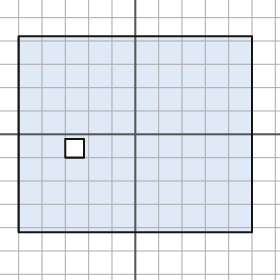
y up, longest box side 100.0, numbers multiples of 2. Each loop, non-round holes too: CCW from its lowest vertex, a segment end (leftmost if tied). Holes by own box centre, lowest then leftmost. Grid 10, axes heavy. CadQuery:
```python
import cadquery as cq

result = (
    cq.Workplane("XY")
    .moveTo(-50.0, -42.0)
    .lineTo(50.0, -42.0)
    .lineTo(50.0, 42.0)
    .lineTo(-50.0, 42.0)
    .close()
    .moveTo(-30.0, -10.0)
    .lineTo(-22.0, -10.0)
    .lineTo(-22.0, -2.0)
    .lineTo(-30.0, -2.0)
    .close()
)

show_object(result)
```